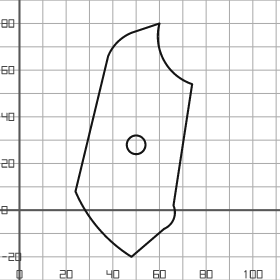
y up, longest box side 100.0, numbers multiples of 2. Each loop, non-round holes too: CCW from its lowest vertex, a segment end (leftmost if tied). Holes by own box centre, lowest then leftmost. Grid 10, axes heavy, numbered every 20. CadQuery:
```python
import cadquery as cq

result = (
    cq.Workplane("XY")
    .moveTo(48.0, -20.0)
    .lineTo(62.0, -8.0)
    .threePointArc((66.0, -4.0), (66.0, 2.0))
    .lineTo(74.0, 54.0)
    .threePointArc((62.0, 64.0), (60.0, 80.0))
    .lineTo(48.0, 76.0)
    .threePointArc((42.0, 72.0), (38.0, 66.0))
    .lineTo(24.0, 8.0)
    .threePointArc((34.0, -8.0), (48.0, -20.0))
    .close()
    .moveTo(50.0, 28.0)
    .circle(4.0)
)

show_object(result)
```